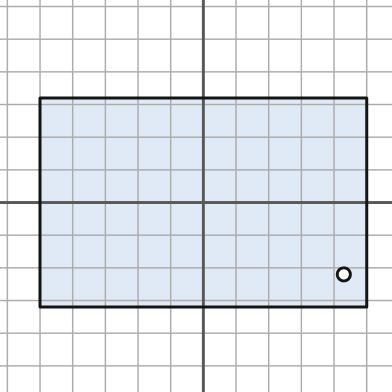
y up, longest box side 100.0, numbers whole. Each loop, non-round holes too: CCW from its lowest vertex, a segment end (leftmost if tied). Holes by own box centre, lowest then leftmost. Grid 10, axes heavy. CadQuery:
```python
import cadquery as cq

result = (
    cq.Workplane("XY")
    .moveTo(-50.0, -32.0)
    .lineTo(50.0, -32.0)
    .lineTo(50.0, 32.0)
    .lineTo(-50.0, 32.0)
    .close()
    .moveTo(43.0, -22.0)
    .circle(2.0)
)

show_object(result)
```